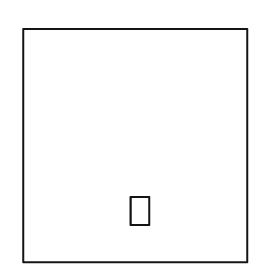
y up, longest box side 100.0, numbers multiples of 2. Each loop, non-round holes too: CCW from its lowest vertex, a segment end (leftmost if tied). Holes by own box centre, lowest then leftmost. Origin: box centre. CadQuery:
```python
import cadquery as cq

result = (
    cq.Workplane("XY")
    .moveTo(-48.0, -50.0)
    .lineTo(48.0, -50.0)
    .lineTo(48.0, 50.0)
    .lineTo(-48.0, 50.0)
    .close()
    .moveTo(-2.0, -34.0)
    .lineTo(6.0, -34.0)
    .lineTo(6.0, -22.0)
    .lineTo(-2.0, -22.0)
    .close()
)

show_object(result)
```